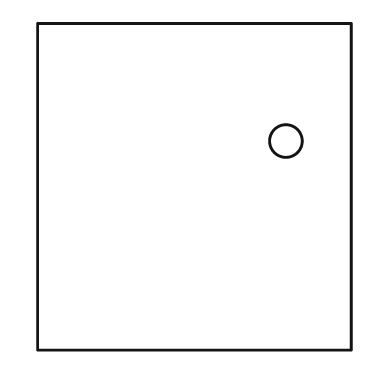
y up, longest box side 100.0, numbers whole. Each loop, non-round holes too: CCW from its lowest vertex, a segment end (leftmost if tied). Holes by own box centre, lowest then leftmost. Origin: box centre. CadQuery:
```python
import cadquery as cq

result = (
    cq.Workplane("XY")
    .moveTo(-48.0, -50.0)
    .lineTo(48.0, -50.0)
    .lineTo(48.0, 50.0)
    .lineTo(-48.0, 50.0)
    .close()
    .moveTo(28.0, 14.0)
    .circle(5.0)
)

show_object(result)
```